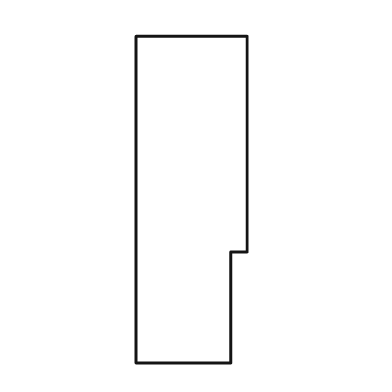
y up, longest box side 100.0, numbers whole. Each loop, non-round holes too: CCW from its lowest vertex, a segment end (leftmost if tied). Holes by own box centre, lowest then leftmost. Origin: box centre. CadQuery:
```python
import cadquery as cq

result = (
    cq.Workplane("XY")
    .moveTo(-17.0, -50.0)
    .lineTo(12.0, -50.0)
    .lineTo(12.0, -16.0)
    .lineTo(17.0, -16.0)
    .lineTo(17.0, 50.0)
    .lineTo(-17.0, 50.0)
    .close()
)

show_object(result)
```